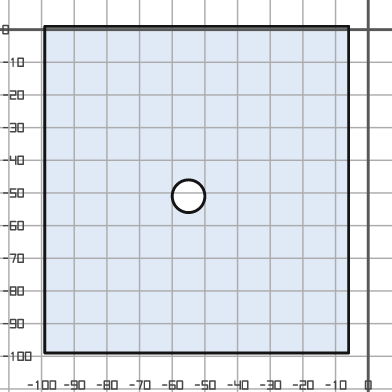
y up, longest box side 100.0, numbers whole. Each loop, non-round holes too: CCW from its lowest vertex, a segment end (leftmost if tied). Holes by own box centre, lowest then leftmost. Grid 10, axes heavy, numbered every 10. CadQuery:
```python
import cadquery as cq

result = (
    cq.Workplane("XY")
    .moveTo(-99.0, -99.0)
    .lineTo(-6.0, -99.0)
    .lineTo(-6.0, 1.0)
    .lineTo(-99.0, 1.0)
    .close()
    .moveTo(-55.0, -51.0)
    .circle(5.0)
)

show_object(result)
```